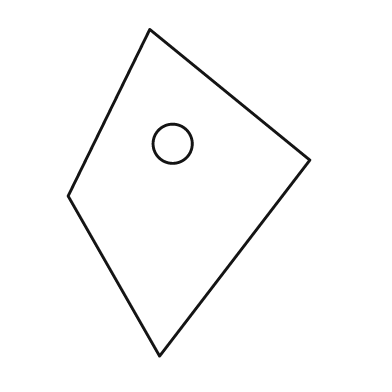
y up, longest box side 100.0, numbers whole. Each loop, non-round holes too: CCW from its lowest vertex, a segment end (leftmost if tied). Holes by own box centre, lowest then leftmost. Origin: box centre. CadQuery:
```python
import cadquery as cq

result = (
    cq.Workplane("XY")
    .moveTo(-9.0, -50.0)
    .lineTo(37.0, 10.0)
    .lineTo(-12.0, 50.0)
    .lineTo(-37.0, -1.0)
    .close()
    .moveTo(-5.0, 15.0)
    .circle(6.0)
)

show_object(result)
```